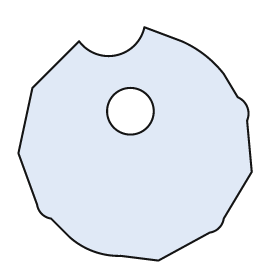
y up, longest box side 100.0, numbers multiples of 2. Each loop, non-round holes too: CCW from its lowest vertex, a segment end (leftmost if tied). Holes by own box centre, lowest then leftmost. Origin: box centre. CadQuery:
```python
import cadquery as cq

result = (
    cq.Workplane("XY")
    .moveTo(10.0, -50.0)
    .lineTo(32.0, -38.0)
    .threePointArc((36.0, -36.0), (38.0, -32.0))
    .lineTo(50.0, -12.0)
    .lineTo(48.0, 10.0)
    .threePointArc((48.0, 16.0), (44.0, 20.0))
    .lineTo(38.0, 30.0)
    .threePointArc((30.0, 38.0), (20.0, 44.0))
    .lineTo(4.0, 50.0)
    .threePointArc((-8.0, 38.0), (-24.0, 44.0))
    .lineTo(-44.0, 24.0)
    .lineTo(-50.0, -4.0)
    .lineTo(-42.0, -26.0)
    .threePointArc((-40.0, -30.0), (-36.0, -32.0))
    .lineTo(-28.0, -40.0)
    .threePointArc((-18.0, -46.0), (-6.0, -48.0))
    .close()
    .moveTo(-2.0, 14.0)
    .circle(10.0)
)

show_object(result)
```